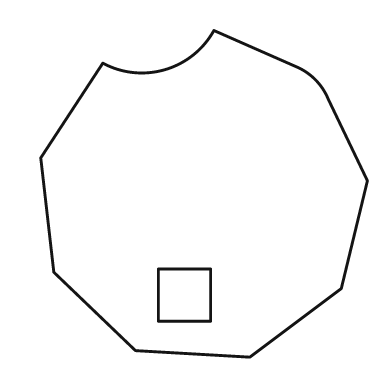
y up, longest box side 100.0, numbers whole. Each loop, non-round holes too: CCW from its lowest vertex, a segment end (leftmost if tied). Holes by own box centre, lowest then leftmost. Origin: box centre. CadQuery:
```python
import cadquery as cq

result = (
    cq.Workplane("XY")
    .moveTo(14.0, -50.0)
    .lineTo(42.0, -29.0)
    .lineTo(50.0, 4.0)
    .lineTo(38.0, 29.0)
    .threePointArc((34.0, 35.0), (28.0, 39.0))
    .lineTo(3.0, 50.0)
    .threePointArc((-12.0, 38.0), (-31.0, 40.0))
    .lineTo(-50.0, 11.0)
    .lineTo(-46.0, -24.0)
    .lineTo(-21.0, -48.0)
    .close()
    .moveTo(-14.0, -39.0)
    .lineTo(2.0, -39.0)
    .lineTo(2.0, -23.0)
    .lineTo(-14.0, -23.0)
    .close()
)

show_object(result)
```